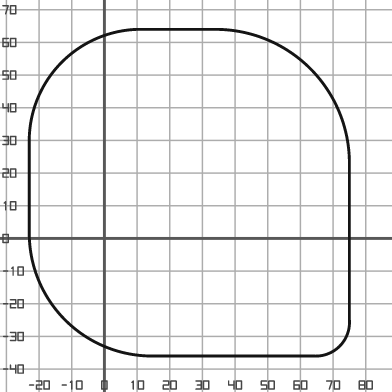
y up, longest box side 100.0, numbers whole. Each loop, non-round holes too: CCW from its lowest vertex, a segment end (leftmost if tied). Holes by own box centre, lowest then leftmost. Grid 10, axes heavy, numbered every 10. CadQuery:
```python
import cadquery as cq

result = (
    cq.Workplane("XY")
    .moveTo(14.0, -36.0)
    .lineTo(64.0, -36.0)
    .threePointArc((72.0, -33.0), (75.0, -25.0))
    .lineTo(75.0, 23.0)
    .threePointArc((63.0, 52.0), (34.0, 64.0))
    .lineTo(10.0, 64.0)
    .threePointArc((-13.0, 54.0), (-23.0, 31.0))
    .lineTo(-23.0, 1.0)
    .threePointArc((-12.0, -25.0), (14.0, -36.0))
    .close()
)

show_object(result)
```